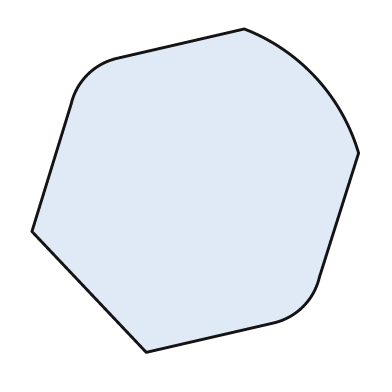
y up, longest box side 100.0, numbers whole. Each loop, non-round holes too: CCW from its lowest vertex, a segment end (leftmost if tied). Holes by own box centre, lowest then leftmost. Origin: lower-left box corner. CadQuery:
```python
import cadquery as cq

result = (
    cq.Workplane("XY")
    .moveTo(35.0, 0.0)
    .lineTo(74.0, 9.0)
    .threePointArc((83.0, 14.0), (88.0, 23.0))
    .lineTo(100.0, 61.0)
    .threePointArc((87.0, 84.0), (65.0, 99.0))
    .lineTo(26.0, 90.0)
    .threePointArc((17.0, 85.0), (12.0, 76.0))
    .lineTo(0.0, 37.0)
    .close()
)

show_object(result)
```